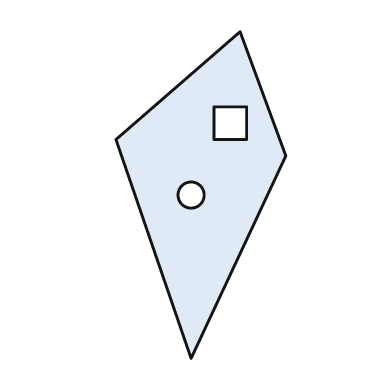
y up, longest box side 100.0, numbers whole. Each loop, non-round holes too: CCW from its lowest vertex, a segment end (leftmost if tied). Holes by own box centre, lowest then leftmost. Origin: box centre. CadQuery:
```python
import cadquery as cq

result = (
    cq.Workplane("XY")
    .moveTo(-3.0, -50.0)
    .lineTo(26.0, 12.0)
    .lineTo(12.0, 50.0)
    .lineTo(-26.0, 17.0)
    .close()
    .moveTo(-3.0, 0.0)
    .circle(4.0)
    .moveTo(4.0, 17.0)
    .lineTo(14.0, 17.0)
    .lineTo(14.0, 27.0)
    .lineTo(4.0, 27.0)
    .close()
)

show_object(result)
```